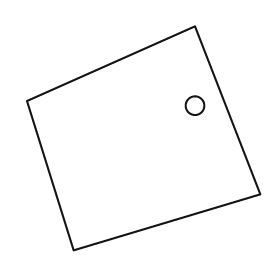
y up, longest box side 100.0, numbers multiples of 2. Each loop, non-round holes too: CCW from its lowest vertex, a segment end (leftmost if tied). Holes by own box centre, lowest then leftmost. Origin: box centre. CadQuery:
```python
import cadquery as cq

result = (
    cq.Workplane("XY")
    .moveTo(-30.0, -48.0)
    .lineTo(50.0, -24.0)
    .lineTo(22.0, 48.0)
    .lineTo(-50.0, 16.0)
    .close()
    .moveTo(22.0, 14.0)
    .circle(4.0)
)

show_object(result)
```